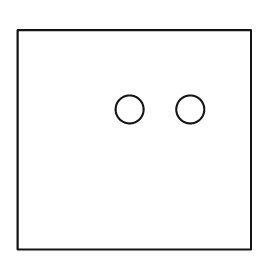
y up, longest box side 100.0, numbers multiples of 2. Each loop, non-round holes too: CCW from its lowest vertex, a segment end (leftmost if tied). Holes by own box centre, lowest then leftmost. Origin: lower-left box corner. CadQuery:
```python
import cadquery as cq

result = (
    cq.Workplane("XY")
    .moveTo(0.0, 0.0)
    .lineTo(100.0, 0.0)
    .lineTo(100.0, 94.0)
    .lineTo(0.0, 94.0)
    .close()
    .moveTo(48.0, 60.0)
    .circle(6.0)
    .moveTo(74.0, 60.0)
    .circle(6.0)
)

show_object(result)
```